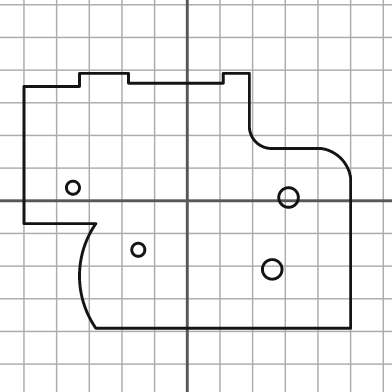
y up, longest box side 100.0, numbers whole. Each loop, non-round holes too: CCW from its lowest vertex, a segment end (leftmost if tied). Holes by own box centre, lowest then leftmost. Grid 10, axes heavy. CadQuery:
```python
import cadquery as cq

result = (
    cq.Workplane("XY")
    .moveTo(-28.0, -39.0)
    .lineTo(50.0, -39.0)
    .lineTo(50.0, 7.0)
    .threePointArc((47.0, 13.0), (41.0, 16.0))
    .lineTo(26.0, 16.0)
    .threePointArc((21.0, 18.0), (19.0, 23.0))
    .lineTo(19.0, 39.0)
    .lineTo(11.0, 39.0)
    .lineTo(11.0, 36.0)
    .lineTo(-18.0, 36.0)
    .lineTo(-18.0, 39.0)
    .lineTo(-33.0, 39.0)
    .lineTo(-33.0, 35.0)
    .lineTo(-50.0, 35.0)
    .lineTo(-50.0, -7.0)
    .lineTo(-28.0, -7.0)
    .threePointArc((-33.0, -23.0), (-28.0, -39.0))
    .close()
    .moveTo(26.0, -21.0)
    .circle(3.0)
    .moveTo(-15.0, -15.0)
    .circle(2.0)
    .moveTo(31.0, 1.0)
    .circle(3.0)
    .moveTo(-35.0, 4.0)
    .circle(2.0)
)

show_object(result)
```